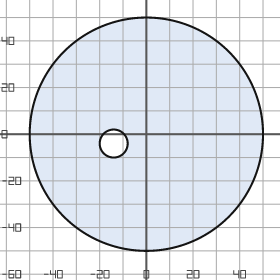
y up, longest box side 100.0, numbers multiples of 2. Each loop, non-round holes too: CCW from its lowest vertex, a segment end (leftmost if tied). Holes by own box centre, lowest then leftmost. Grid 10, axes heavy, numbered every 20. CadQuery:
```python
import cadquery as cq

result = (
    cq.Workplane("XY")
    .moveTo(0.0, 0.0)
    .circle(50.0)
    .moveTo(-14.0, -4.0)
    .circle(6.0)
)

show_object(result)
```